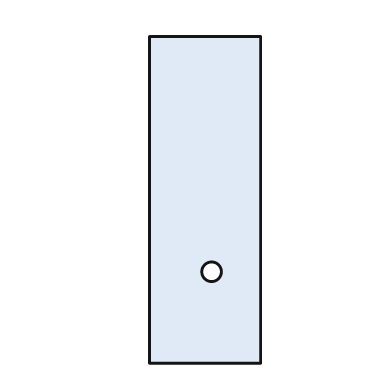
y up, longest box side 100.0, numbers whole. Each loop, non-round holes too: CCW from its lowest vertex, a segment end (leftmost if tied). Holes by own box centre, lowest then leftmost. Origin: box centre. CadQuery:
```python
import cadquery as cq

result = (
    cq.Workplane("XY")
    .moveTo(-17.0, -50.0)
    .lineTo(17.0, -50.0)
    .lineTo(17.0, 50.0)
    .lineTo(-17.0, 50.0)
    .close()
    .moveTo(2.0, -22.0)
    .circle(3.0)
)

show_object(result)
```